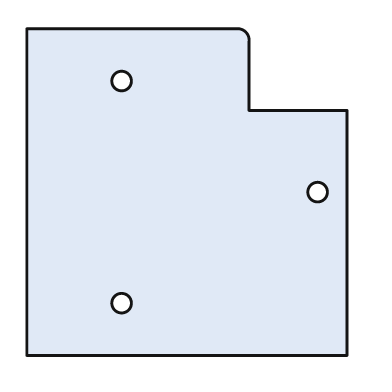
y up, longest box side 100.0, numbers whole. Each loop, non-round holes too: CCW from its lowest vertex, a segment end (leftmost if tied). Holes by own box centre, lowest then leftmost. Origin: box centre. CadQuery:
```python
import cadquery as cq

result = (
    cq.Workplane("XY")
    .moveTo(-49.0, -50.0)
    .lineTo(49.0, -50.0)
    .lineTo(49.0, 25.0)
    .lineTo(19.0, 25.0)
    .lineTo(19.0, 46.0)
    .threePointArc((18.0, 49.0), (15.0, 50.0))
    .lineTo(-49.0, 50.0)
    .close()
    .moveTo(-20.0, -34.0)
    .circle(3.0)
    .moveTo(40.0, 0.0)
    .circle(3.0)
    .moveTo(-20.0, 34.0)
    .circle(3.0)
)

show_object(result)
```